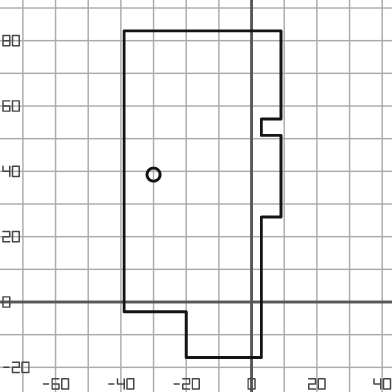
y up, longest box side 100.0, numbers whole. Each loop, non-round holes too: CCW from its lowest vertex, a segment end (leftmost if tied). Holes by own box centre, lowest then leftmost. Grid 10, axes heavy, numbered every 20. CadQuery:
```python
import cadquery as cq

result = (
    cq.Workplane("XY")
    .moveTo(-20.0, -17.0)
    .lineTo(3.0, -17.0)
    .lineTo(3.0, 26.0)
    .lineTo(9.0, 26.0)
    .lineTo(9.0, 51.0)
    .lineTo(3.0, 51.0)
    .lineTo(3.0, 56.0)
    .lineTo(9.0, 56.0)
    .lineTo(9.0, 83.0)
    .lineTo(-39.0, 83.0)
    .lineTo(-39.0, -3.0)
    .lineTo(-20.0, -3.0)
    .close()
    .moveTo(-30.0, 39.0)
    .circle(2.0)
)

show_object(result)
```